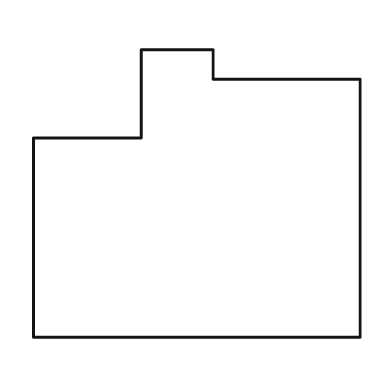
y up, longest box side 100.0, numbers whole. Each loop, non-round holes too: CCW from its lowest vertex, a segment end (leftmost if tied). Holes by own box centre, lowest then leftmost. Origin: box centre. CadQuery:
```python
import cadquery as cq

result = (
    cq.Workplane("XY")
    .moveTo(-50.0, -44.0)
    .lineTo(50.0, -44.0)
    .lineTo(50.0, 35.0)
    .lineTo(5.0, 35.0)
    .lineTo(5.0, 44.0)
    .lineTo(-17.0, 44.0)
    .lineTo(-17.0, 17.0)
    .lineTo(-50.0, 17.0)
    .close()
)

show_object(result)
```